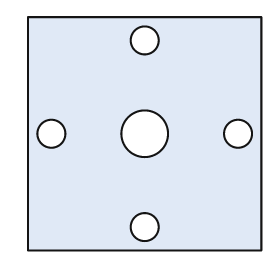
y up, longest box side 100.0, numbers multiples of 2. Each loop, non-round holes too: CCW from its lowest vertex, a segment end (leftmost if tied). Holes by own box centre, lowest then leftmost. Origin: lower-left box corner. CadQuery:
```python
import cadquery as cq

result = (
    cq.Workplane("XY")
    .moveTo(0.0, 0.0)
    .lineTo(100.0, 0.0)
    .lineTo(100.0, 100.0)
    .lineTo(0.0, 100.0)
    .close()
    .moveTo(50.0, 10.0)
    .circle(6.0)
    .moveTo(10.0, 50.0)
    .circle(6.0)
    .moveTo(50.0, 50.0)
    .circle(10.0)
    .moveTo(90.0, 50.0)
    .circle(6.0)
    .moveTo(50.0, 90.0)
    .circle(6.0)
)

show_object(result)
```